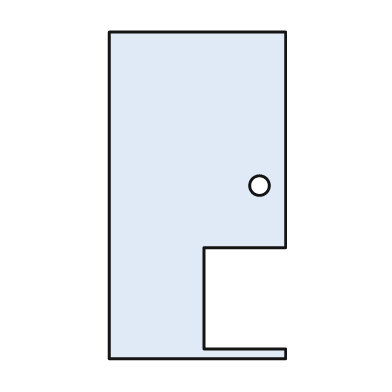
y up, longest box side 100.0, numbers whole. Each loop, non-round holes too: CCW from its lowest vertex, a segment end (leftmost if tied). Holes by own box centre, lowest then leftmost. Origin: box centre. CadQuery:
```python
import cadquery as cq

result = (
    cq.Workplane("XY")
    .moveTo(-27.0, -50.0)
    .lineTo(27.0, -50.0)
    .lineTo(27.0, -47.0)
    .lineTo(2.0, -47.0)
    .lineTo(2.0, -16.0)
    .lineTo(27.0, -16.0)
    .lineTo(27.0, 50.0)
    .lineTo(-27.0, 50.0)
    .close()
    .moveTo(19.0, 3.0)
    .circle(3.0)
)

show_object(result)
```